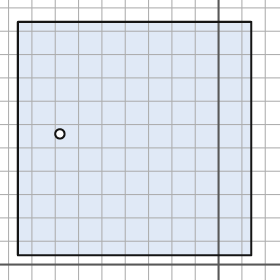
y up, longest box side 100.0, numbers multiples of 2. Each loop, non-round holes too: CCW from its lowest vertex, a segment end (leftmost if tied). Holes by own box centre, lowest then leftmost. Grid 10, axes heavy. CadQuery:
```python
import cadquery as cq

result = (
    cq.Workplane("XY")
    .moveTo(-86.0, 4.0)
    .lineTo(14.0, 4.0)
    .lineTo(14.0, 104.0)
    .lineTo(-86.0, 104.0)
    .close()
    .moveTo(-68.0, 56.0)
    .circle(2.0)
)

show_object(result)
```